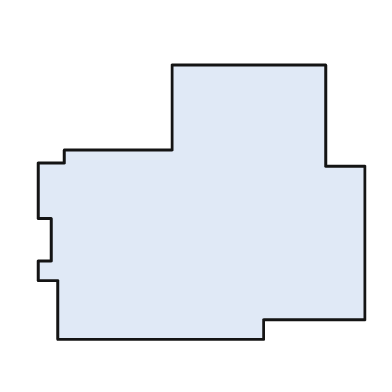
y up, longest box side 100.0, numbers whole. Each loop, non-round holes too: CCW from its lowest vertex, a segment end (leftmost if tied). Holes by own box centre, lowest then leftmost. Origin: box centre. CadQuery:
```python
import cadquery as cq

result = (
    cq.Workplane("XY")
    .moveTo(-44.0, -42.0)
    .lineTo(19.0, -42.0)
    .lineTo(19.0, -36.0)
    .lineTo(50.0, -36.0)
    .lineTo(50.0, 11.0)
    .lineTo(38.0, 11.0)
    .lineTo(38.0, 42.0)
    .lineTo(-9.0, 42.0)
    .lineTo(-9.0, 16.0)
    .lineTo(-42.0, 16.0)
    .lineTo(-42.0, 12.0)
    .lineTo(-50.0, 12.0)
    .lineTo(-50.0, -5.0)
    .lineTo(-46.0, -5.0)
    .lineTo(-46.0, -18.0)
    .lineTo(-50.0, -18.0)
    .lineTo(-50.0, -24.0)
    .lineTo(-44.0, -24.0)
    .close()
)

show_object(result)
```